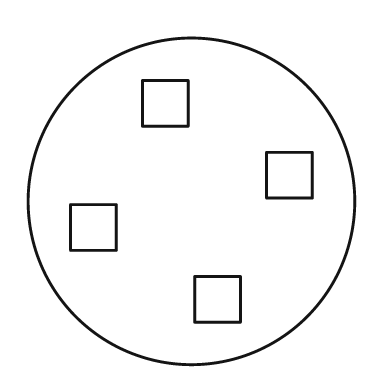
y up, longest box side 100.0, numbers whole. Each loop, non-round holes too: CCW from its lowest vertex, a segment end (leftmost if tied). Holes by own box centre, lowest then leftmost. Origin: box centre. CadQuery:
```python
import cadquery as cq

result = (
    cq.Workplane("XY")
    .moveTo(0.0, 0.0)
    .circle(50.0)
    .moveTo(1.0, -37.0)
    .lineTo(15.0, -37.0)
    .lineTo(15.0, -23.0)
    .lineTo(1.0, -23.0)
    .close()
    .moveTo(-37.0, -15.0)
    .lineTo(-23.0, -15.0)
    .lineTo(-23.0, -1.0)
    .lineTo(-37.0, -1.0)
    .close()
    .moveTo(23.0, 1.0)
    .lineTo(37.0, 1.0)
    .lineTo(37.0, 15.0)
    .lineTo(23.0, 15.0)
    .close()
    .moveTo(-15.0, 23.0)
    .lineTo(-1.0, 23.0)
    .lineTo(-1.0, 37.0)
    .lineTo(-15.0, 37.0)
    .close()
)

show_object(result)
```